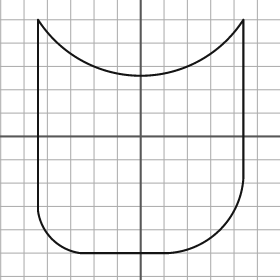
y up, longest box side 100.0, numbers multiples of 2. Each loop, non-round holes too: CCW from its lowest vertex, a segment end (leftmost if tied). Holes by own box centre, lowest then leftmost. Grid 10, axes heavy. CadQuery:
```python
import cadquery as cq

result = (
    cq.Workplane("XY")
    .moveTo(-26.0, -50.0)
    .lineTo(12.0, -50.0)
    .threePointArc((34.0, -40.0), (44.0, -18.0))
    .lineTo(44.0, 50.0)
    .threePointArc((0.0, 26.0), (-44.0, 50.0))
    .lineTo(-44.0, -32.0)
    .threePointArc((-38.0, -44.0), (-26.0, -50.0))
    .close()
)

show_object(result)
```